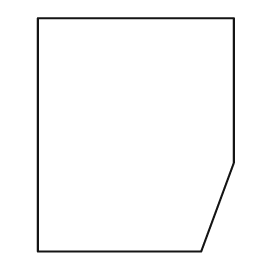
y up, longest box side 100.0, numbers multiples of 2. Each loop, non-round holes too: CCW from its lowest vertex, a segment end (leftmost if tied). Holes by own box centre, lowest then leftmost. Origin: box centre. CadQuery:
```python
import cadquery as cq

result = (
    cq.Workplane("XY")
    .moveTo(-42.0, -50.0)
    .lineTo(28.0, -50.0)
    .lineTo(42.0, -12.0)
    .lineTo(42.0, 50.0)
    .lineTo(-42.0, 50.0)
    .close()
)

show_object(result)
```